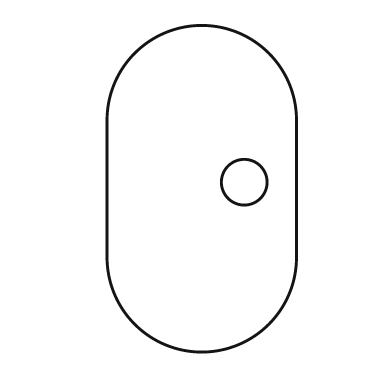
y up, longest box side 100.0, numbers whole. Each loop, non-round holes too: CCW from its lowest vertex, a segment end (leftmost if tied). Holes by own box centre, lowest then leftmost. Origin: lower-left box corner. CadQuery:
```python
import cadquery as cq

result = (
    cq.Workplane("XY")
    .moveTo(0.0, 29.0)
    .threePointArc((29.0, 0.0), (58.0, 29.0))
    .lineTo(58.0, 71.0)
    .threePointArc((29.0, 100.0), (0.0, 71.0))
    .close()
    .moveTo(42.0, 52.0)
    .circle(7.0)
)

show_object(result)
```